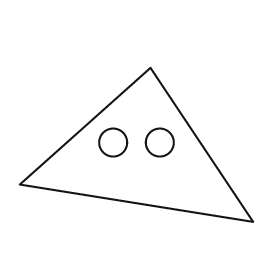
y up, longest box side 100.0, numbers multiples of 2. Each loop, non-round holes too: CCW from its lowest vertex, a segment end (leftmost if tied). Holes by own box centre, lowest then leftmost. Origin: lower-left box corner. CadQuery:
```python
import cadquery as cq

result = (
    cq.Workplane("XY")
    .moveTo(100.0, 0.0)
    .lineTo(56.0, 66.0)
    .lineTo(0.0, 16.0)
    .close()
    .moveTo(40.0, 34.0)
    .circle(6.0)
    .moveTo(60.0, 34.0)
    .circle(6.0)
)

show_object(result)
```